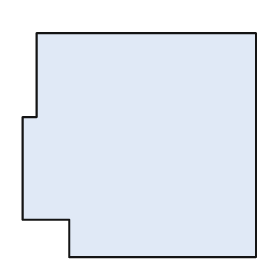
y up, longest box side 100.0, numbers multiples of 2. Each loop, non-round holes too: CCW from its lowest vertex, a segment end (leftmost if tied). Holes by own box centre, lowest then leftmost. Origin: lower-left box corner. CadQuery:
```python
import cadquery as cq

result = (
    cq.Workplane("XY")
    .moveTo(20.0, 0.0)
    .lineTo(100.0, 0.0)
    .lineTo(100.0, 96.0)
    .lineTo(6.0, 96.0)
    .lineTo(6.0, 60.0)
    .lineTo(0.0, 60.0)
    .lineTo(0.0, 16.0)
    .lineTo(20.0, 16.0)
    .close()
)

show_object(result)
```